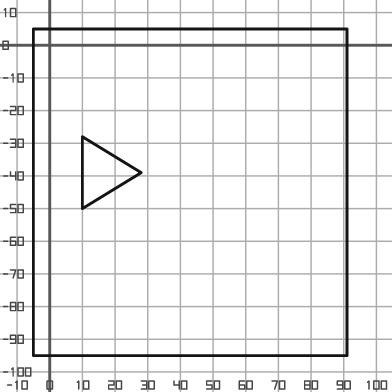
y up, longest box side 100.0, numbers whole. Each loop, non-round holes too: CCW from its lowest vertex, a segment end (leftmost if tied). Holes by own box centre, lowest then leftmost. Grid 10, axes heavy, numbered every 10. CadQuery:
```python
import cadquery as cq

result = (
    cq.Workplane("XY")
    .moveTo(-5.0, -95.0)
    .lineTo(91.0, -95.0)
    .lineTo(91.0, 5.0)
    .lineTo(-5.0, 5.0)
    .close()
    .moveTo(10.0, -50.0)
    .lineTo(28.0, -39.0)
    .lineTo(10.0, -28.0)
    .close()
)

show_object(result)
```